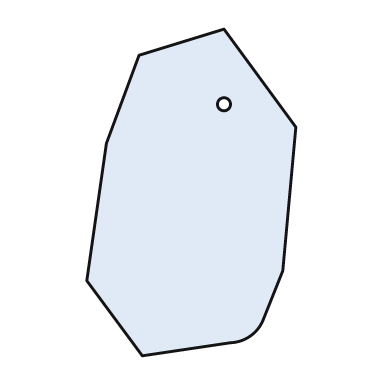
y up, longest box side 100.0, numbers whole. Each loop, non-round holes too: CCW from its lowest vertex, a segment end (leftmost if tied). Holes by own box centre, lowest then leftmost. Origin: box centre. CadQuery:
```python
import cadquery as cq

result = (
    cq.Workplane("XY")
    .moveTo(-15.0, -50.0)
    .lineTo(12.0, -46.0)
    .threePointArc((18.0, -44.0), (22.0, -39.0))
    .lineTo(28.0, -24.0)
    .lineTo(32.0, 20.0)
    .lineTo(10.0, 50.0)
    .lineTo(-16.0, 42.0)
    .lineTo(-26.0, 15.0)
    .lineTo(-32.0, -27.0)
    .close()
    .moveTo(10.0, 27.0)
    .circle(2.0)
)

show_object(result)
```